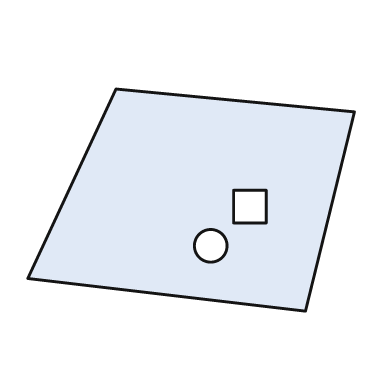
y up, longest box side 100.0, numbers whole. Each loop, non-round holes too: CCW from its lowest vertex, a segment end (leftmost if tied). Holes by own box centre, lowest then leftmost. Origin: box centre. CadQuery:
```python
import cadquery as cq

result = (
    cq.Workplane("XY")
    .moveTo(35.0, -34.0)
    .lineTo(50.0, 27.0)
    .lineTo(-23.0, 34.0)
    .lineTo(-50.0, -24.0)
    .close()
    .moveTo(6.0, -14.0)
    .circle(5.0)
    .moveTo(13.0, -7.0)
    .lineTo(23.0, -7.0)
    .lineTo(23.0, 3.0)
    .lineTo(13.0, 3.0)
    .close()
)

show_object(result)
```